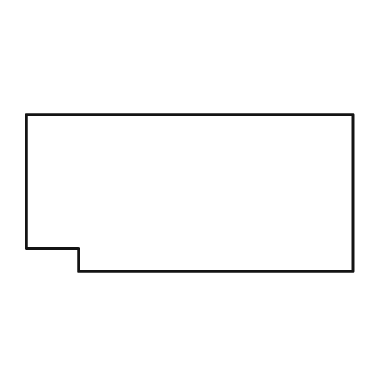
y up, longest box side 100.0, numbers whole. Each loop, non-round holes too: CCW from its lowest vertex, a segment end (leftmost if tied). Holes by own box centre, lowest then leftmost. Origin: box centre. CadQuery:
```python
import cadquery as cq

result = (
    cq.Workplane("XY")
    .moveTo(-34.0, -24.0)
    .lineTo(50.0, -24.0)
    .lineTo(50.0, 24.0)
    .lineTo(-50.0, 24.0)
    .lineTo(-50.0, -17.0)
    .lineTo(-34.0, -17.0)
    .close()
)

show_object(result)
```